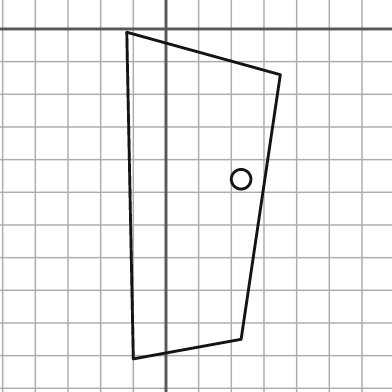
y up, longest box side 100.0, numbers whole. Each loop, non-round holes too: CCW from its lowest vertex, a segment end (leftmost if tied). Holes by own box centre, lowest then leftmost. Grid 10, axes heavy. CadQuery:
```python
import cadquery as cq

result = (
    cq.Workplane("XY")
    .moveTo(-10.0, -101.0)
    .lineTo(23.0, -95.0)
    .lineTo(35.0, -14.0)
    .lineTo(-12.0, -1.0)
    .close()
    .moveTo(23.0, -46.0)
    .circle(3.0)
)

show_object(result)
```